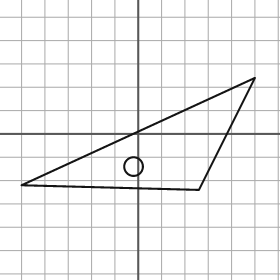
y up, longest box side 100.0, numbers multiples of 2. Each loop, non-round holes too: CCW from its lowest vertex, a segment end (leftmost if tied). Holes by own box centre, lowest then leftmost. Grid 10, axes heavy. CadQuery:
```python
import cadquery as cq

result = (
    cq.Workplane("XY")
    .moveTo(26.0, -24.0)
    .lineTo(50.0, 24.0)
    .lineTo(-50.0, -22.0)
    .close()
    .moveTo(-2.0, -14.0)
    .circle(4.0)
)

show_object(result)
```